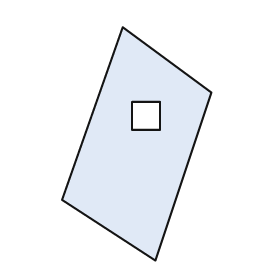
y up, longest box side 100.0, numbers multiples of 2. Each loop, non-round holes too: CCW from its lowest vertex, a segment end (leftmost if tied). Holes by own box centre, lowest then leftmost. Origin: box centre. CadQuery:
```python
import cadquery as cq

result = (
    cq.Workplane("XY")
    .moveTo(8.0, -50.0)
    .lineTo(32.0, 22.0)
    .lineTo(-6.0, 50.0)
    .lineTo(-32.0, -24.0)
    .close()
    .moveTo(-2.0, 6.0)
    .lineTo(10.0, 6.0)
    .lineTo(10.0, 18.0)
    .lineTo(-2.0, 18.0)
    .close()
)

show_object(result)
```